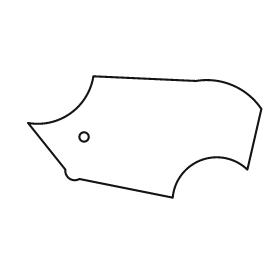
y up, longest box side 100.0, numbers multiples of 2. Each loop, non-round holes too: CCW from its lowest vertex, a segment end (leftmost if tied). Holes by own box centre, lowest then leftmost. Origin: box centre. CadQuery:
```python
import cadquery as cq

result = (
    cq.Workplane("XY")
    .moveTo(12.0, -26.0)
    .threePointArc((24.0, -10.0), (44.0, -14.0))
    .lineTo(50.0, 12.0)
    .threePointArc((38.0, 22.0), (22.0, 24.0))
    .lineTo(-22.0, 26.0)
    .threePointArc((-32.0, 10.0), (-50.0, 6.0))
    .lineTo(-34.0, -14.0)
    .threePointArc((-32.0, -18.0), (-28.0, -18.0))
    .close()
    .moveTo(-26.0, 0.0)
    .circle(2.0)
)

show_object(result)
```